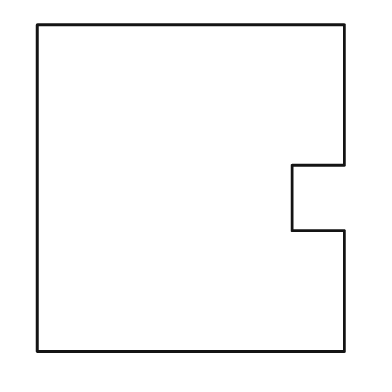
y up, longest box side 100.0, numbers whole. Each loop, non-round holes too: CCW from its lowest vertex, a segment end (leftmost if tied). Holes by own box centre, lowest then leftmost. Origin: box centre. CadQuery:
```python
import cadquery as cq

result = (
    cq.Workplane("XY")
    .moveTo(-47.0, -50.0)
    .lineTo(47.0, -50.0)
    .lineTo(47.0, -13.0)
    .lineTo(31.0, -13.0)
    .lineTo(31.0, 7.0)
    .lineTo(47.0, 7.0)
    .lineTo(47.0, 50.0)
    .lineTo(-47.0, 50.0)
    .close()
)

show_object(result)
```